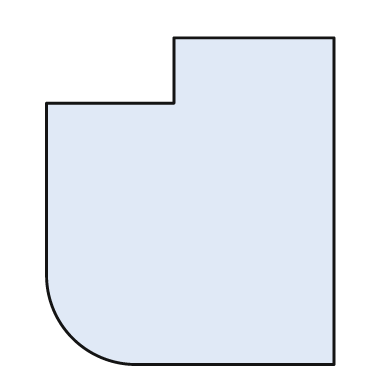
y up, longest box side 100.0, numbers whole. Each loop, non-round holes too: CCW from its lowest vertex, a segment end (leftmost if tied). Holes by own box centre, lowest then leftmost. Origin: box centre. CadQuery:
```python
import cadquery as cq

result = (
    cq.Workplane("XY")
    .moveTo(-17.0, -50.0)
    .lineTo(44.0, -50.0)
    .lineTo(44.0, 50.0)
    .lineTo(-5.0, 50.0)
    .lineTo(-5.0, 30.0)
    .lineTo(-44.0, 30.0)
    .lineTo(-44.0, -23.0)
    .threePointArc((-36.0, -42.0), (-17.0, -50.0))
    .close()
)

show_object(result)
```